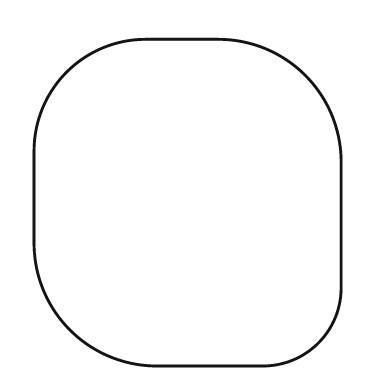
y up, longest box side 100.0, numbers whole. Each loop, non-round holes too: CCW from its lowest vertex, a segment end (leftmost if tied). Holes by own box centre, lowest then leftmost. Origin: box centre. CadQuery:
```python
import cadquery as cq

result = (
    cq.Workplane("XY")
    .moveTo(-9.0, -50.0)
    .lineTo(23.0, -50.0)
    .threePointArc((40.0, -43.0), (47.0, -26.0))
    .lineTo(47.0, 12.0)
    .threePointArc((36.0, 39.0), (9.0, 50.0))
    .lineTo(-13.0, 50.0)
    .threePointArc((-37.0, 40.0), (-47.0, 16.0))
    .lineTo(-47.0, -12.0)
    .threePointArc((-36.0, -39.0), (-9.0, -50.0))
    .close()
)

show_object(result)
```